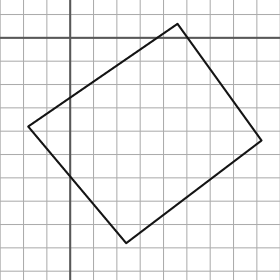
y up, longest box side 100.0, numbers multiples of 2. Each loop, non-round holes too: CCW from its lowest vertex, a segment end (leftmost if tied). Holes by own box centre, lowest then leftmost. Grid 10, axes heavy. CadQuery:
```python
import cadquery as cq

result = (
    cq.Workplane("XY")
    .moveTo(24.0, -88.0)
    .lineTo(82.0, -44.0)
    .lineTo(46.0, 6.0)
    .lineTo(-18.0, -38.0)
    .close()
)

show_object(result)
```